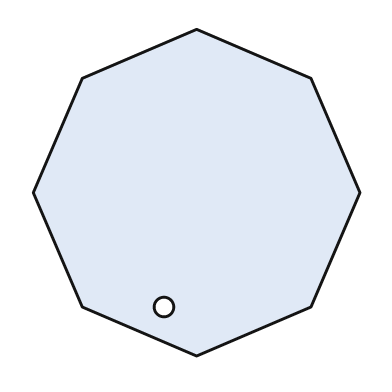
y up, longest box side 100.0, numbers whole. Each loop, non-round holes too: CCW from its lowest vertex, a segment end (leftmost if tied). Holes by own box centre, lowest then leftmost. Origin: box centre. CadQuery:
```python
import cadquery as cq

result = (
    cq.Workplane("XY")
    .moveTo(0.0, -50.0)
    .lineTo(35.0, -35.0)
    .lineTo(50.0, 0.0)
    .lineTo(35.0, 35.0)
    .lineTo(0.0, 50.0)
    .lineTo(-35.0, 35.0)
    .lineTo(-50.0, 0.0)
    .lineTo(-35.0, -35.0)
    .close()
    .moveTo(-10.0, -35.0)
    .circle(3.0)
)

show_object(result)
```